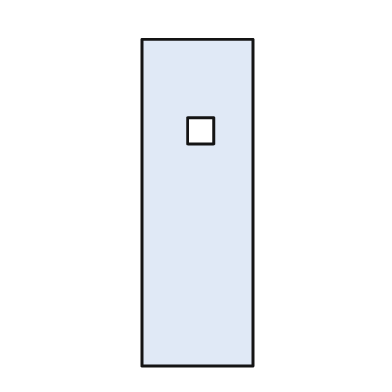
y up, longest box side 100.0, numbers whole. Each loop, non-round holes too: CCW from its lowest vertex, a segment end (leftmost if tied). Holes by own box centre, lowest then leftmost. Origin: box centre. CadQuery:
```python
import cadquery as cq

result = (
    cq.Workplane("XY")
    .moveTo(-17.0, -50.0)
    .lineTo(17.0, -50.0)
    .lineTo(17.0, 50.0)
    .lineTo(-17.0, 50.0)
    .close()
    .moveTo(-3.0, 18.0)
    .lineTo(5.0, 18.0)
    .lineTo(5.0, 26.0)
    .lineTo(-3.0, 26.0)
    .close()
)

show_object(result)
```